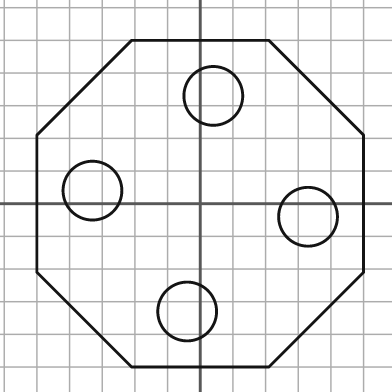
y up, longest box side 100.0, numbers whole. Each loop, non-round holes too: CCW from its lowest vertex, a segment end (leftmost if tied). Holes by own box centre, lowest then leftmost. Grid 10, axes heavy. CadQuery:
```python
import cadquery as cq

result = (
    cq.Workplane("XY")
    .moveTo(-21.0, -50.0)
    .lineTo(21.0, -50.0)
    .lineTo(50.0, -21.0)
    .lineTo(50.0, 21.0)
    .lineTo(21.0, 50.0)
    .lineTo(-21.0, 50.0)
    .lineTo(-50.0, 21.0)
    .lineTo(-50.0, -21.0)
    .close()
    .moveTo(-4.0, -33.0)
    .circle(9.0)
    .moveTo(33.0, -4.0)
    .circle(9.0)
    .moveTo(-33.0, 4.0)
    .circle(9.0)
    .moveTo(4.0, 33.0)
    .circle(9.0)
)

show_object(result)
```